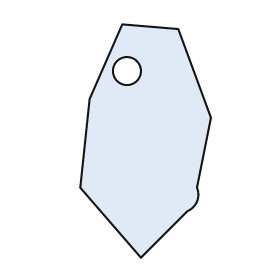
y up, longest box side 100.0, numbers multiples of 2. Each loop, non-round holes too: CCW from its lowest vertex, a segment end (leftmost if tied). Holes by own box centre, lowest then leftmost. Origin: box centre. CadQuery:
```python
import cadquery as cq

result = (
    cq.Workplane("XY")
    .moveTo(-2.0, -50.0)
    .lineTo(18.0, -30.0)
    .threePointArc((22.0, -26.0), (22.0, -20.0))
    .lineTo(28.0, 10.0)
    .lineTo(14.0, 48.0)
    .lineTo(-10.0, 50.0)
    .lineTo(-24.0, 18.0)
    .lineTo(-28.0, -20.0)
    .close()
    .moveTo(-8.0, 30.0)
    .circle(6.0)
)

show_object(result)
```